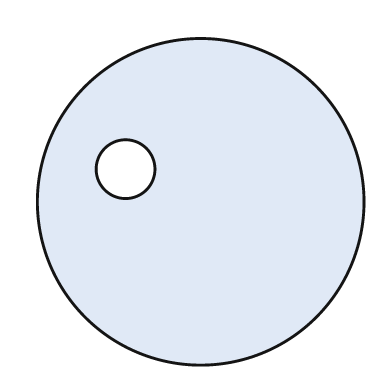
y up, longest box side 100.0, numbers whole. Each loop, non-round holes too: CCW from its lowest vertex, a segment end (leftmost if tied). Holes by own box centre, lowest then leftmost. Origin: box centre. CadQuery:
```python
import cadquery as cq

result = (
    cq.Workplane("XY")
    .moveTo(0.0, 0.0)
    .circle(50.0)
    .moveTo(-23.0, 10.0)
    .circle(9.0)
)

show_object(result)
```